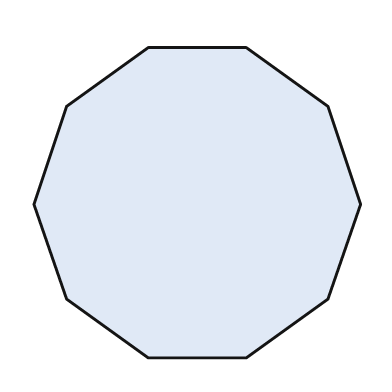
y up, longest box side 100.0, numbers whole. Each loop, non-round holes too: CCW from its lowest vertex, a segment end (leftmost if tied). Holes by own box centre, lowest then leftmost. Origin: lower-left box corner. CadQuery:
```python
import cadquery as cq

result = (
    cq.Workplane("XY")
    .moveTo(35.0, 0.0)
    .lineTo(65.0, 0.0)
    .lineTo(90.0, 18.0)
    .lineTo(100.0, 47.0)
    .lineTo(90.0, 77.0)
    .lineTo(65.0, 95.0)
    .lineTo(35.0, 95.0)
    .lineTo(10.0, 77.0)
    .lineTo(0.0, 47.0)
    .lineTo(10.0, 18.0)
    .close()
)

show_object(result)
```